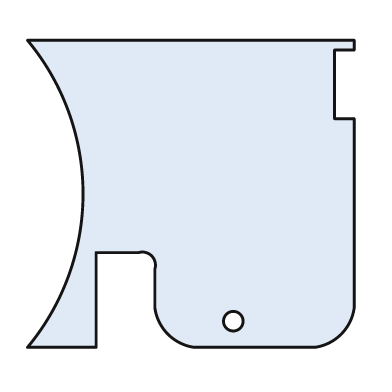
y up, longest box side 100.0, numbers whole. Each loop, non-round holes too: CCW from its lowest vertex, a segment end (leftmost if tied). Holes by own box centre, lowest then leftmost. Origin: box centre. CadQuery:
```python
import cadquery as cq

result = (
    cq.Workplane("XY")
    .moveTo(-50.0, -47.0)
    .lineTo(-29.0, -47.0)
    .lineTo(-29.0, -18.0)
    .lineTo(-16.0, -18.0)
    .threePointArc((-12.0, -19.0), (-11.0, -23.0))
    .lineTo(-11.0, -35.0)
    .threePointArc((-7.0, -43.0), (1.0, -47.0))
    .lineTo(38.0, -47.0)
    .threePointArc((46.0, -43.0), (50.0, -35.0))
    .lineTo(50.0, 23.0)
    .lineTo(44.0, 23.0)
    .lineTo(44.0, 44.0)
    .lineTo(50.0, 44.0)
    .lineTo(50.0, 47.0)
    .lineTo(-50.0, 47.0)
    .threePointArc((-33.0, 0.0), (-50.0, -47.0))
    .close()
    .moveTo(13.0, -39.0)
    .circle(3.0)
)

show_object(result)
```